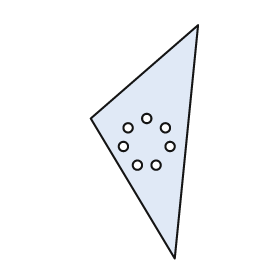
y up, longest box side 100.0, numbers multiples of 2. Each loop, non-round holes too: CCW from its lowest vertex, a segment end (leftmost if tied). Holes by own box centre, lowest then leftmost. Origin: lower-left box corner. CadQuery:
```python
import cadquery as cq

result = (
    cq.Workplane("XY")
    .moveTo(36.0, 0.0)
    .lineTo(46.0, 100.0)
    .lineTo(0.0, 60.0)
    .close()
    .moveTo(20.0, 40.0)
    .circle(2.0)
    .moveTo(28.0, 40.0)
    .circle(2.0)
    .moveTo(14.0, 48.0)
    .circle(2.0)
    .moveTo(34.0, 48.0)
    .circle(2.0)
    .moveTo(16.0, 56.0)
    .circle(2.0)
    .moveTo(32.0, 56.0)
    .circle(2.0)
    .moveTo(24.0, 60.0)
    .circle(2.0)
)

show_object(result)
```